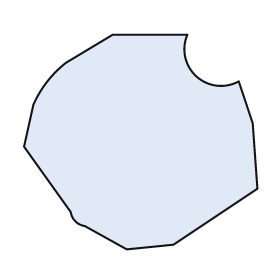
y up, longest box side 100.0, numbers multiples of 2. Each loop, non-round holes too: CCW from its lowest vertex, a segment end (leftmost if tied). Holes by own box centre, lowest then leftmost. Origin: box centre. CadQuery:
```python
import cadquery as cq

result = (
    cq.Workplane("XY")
    .moveTo(-6.0, -46.0)
    .lineTo(14.0, -44.0)
    .lineTo(50.0, -20.0)
    .lineTo(48.0, 8.0)
    .lineTo(42.0, 26.0)
    .threePointArc((24.0, 28.0), (20.0, 46.0))
    .lineTo(-12.0, 46.0)
    .lineTo(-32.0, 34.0)
    .threePointArc((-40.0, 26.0), (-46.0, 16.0))
    .lineTo(-50.0, -2.0)
    .lineTo(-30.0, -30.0)
    .threePointArc((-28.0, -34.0), (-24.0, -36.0))
    .close()
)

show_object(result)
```